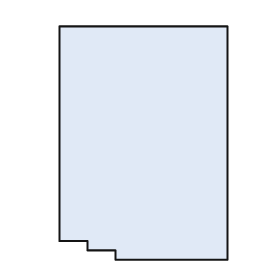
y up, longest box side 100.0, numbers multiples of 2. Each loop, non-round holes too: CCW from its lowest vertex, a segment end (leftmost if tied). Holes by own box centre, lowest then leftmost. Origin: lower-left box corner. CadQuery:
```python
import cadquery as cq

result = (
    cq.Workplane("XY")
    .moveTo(24.0, 0.0)
    .lineTo(72.0, 0.0)
    .lineTo(72.0, 100.0)
    .lineTo(0.0, 100.0)
    .lineTo(0.0, 8.0)
    .lineTo(12.0, 8.0)
    .lineTo(12.0, 4.0)
    .lineTo(24.0, 4.0)
    .close()
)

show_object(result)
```